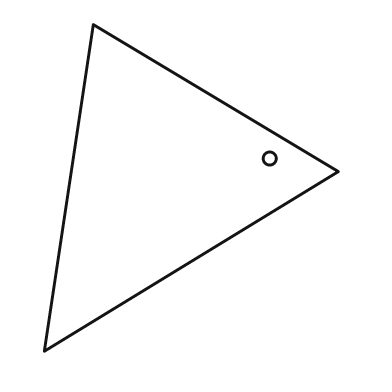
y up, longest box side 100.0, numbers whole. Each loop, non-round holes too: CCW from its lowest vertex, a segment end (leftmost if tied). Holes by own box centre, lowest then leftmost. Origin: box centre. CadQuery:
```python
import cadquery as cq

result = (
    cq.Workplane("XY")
    .moveTo(-45.0, -50.0)
    .lineTo(45.0, 5.0)
    .lineTo(-30.0, 50.0)
    .close()
    .moveTo(24.0, 9.0)
    .circle(2.0)
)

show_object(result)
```